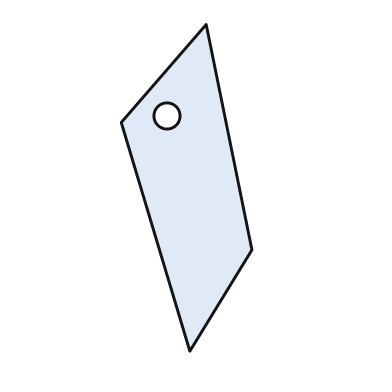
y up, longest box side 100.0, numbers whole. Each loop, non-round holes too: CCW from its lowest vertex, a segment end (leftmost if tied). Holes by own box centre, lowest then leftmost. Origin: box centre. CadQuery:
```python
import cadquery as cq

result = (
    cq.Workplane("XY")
    .moveTo(1.0, -50.0)
    .lineTo(20.0, -19.0)
    .lineTo(6.0, 50.0)
    .lineTo(-20.0, 20.0)
    .close()
    .moveTo(-6.0, 22.0)
    .circle(4.0)
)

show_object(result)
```